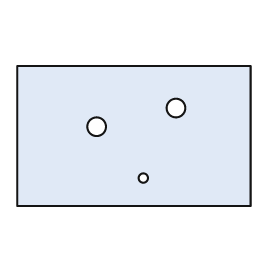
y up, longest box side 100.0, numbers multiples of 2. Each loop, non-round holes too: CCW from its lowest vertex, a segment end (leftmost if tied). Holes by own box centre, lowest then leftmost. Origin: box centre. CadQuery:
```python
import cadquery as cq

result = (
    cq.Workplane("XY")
    .moveTo(-50.0, -30.0)
    .lineTo(50.0, -30.0)
    .lineTo(50.0, 30.0)
    .lineTo(-50.0, 30.0)
    .close()
    .moveTo(4.0, -18.0)
    .circle(2.0)
    .moveTo(-16.0, 4.0)
    .circle(4.0)
    .moveTo(18.0, 12.0)
    .circle(4.0)
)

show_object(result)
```